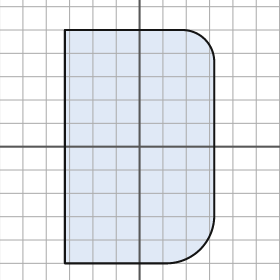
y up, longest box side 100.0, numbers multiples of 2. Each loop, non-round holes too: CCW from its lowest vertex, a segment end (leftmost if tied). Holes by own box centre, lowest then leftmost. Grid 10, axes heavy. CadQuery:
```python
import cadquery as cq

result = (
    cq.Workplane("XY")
    .moveTo(-32.0, -50.0)
    .lineTo(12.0, -50.0)
    .threePointArc((26.0, -44.0), (32.0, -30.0))
    .lineTo(32.0, 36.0)
    .threePointArc((28.0, 46.0), (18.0, 50.0))
    .lineTo(-32.0, 50.0)
    .close()
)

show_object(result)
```